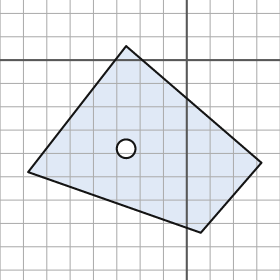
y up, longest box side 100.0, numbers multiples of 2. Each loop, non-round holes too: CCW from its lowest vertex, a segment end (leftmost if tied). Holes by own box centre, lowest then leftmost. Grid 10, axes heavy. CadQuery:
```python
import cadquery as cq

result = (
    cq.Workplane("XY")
    .moveTo(6.0, -74.0)
    .lineTo(32.0, -44.0)
    .lineTo(-26.0, 6.0)
    .lineTo(-68.0, -48.0)
    .close()
    .moveTo(-26.0, -38.0)
    .circle(4.0)
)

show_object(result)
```